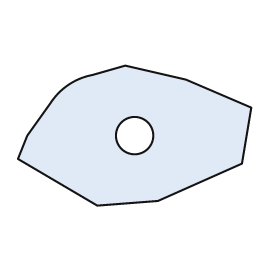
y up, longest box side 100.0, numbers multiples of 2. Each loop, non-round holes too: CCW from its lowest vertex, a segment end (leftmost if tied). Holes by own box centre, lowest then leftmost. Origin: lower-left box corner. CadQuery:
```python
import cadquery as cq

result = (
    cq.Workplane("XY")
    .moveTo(34.0, 0.0)
    .lineTo(60.0, 2.0)
    .lineTo(96.0, 18.0)
    .lineTo(100.0, 42.0)
    .lineTo(72.0, 54.0)
    .lineTo(46.0, 60.0)
    .lineTo(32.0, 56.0)
    .threePointArc((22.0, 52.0), (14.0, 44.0))
    .lineTo(4.0, 30.0)
    .lineTo(0.0, 20.0)
    .close()
    .moveTo(50.0, 30.0)
    .circle(8.0)
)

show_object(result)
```